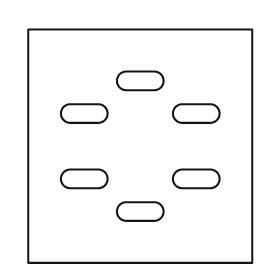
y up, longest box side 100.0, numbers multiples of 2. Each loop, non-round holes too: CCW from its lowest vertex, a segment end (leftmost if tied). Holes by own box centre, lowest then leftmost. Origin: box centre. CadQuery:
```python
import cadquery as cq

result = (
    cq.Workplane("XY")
    .moveTo(-48.0, -50.0)
    .lineTo(48.0, -50.0)
    .lineTo(48.0, 50.0)
    .lineTo(-48.0, 50.0)
    .close()
    .moveTo(-6.0, -32.0)
    .lineTo(6.0, -32.0)
    .threePointArc((10.0, -28.0), (6.0, -24.0))
    .lineTo(-6.0, -24.0)
    .threePointArc((-10.0, -28.0), (-6.0, -32.0))
    .close()
    .moveTo(-30.0, -18.0)
    .lineTo(-18.0, -18.0)
    .threePointArc((-14.0, -14.0), (-18.0, -10.0))
    .lineTo(-30.0, -10.0)
    .threePointArc((-34.0, -14.0), (-30.0, -18.0))
    .close()
    .moveTo(18.0, -18.0)
    .lineTo(30.0, -18.0)
    .threePointArc((34.0, -14.0), (30.0, -10.0))
    .lineTo(18.0, -10.0)
    .threePointArc((14.0, -14.0), (18.0, -18.0))
    .close()
    .moveTo(-30.0, 10.0)
    .lineTo(-18.0, 10.0)
    .threePointArc((-14.0, 14.0), (-18.0, 18.0))
    .lineTo(-30.0, 18.0)
    .threePointArc((-34.0, 14.0), (-30.0, 10.0))
    .close()
    .moveTo(18.0, 10.0)
    .lineTo(30.0, 10.0)
    .threePointArc((34.0, 14.0), (30.0, 18.0))
    .lineTo(18.0, 18.0)
    .threePointArc((14.0, 14.0), (18.0, 10.0))
    .close()
    .moveTo(-6.0, 24.0)
    .lineTo(6.0, 24.0)
    .threePointArc((10.0, 28.0), (6.0, 32.0))
    .lineTo(-6.0, 32.0)
    .threePointArc((-10.0, 28.0), (-6.0, 24.0))
    .close()
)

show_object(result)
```